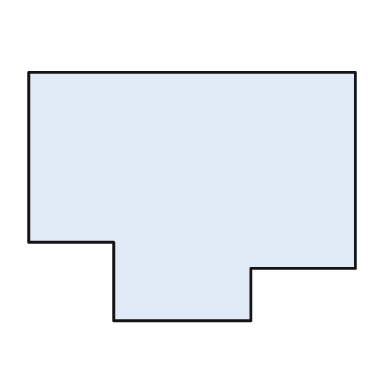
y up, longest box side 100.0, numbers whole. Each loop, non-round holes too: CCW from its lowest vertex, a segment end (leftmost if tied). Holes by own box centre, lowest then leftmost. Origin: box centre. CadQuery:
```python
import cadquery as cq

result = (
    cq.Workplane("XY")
    .moveTo(-24.0, -38.0)
    .lineTo(18.0, -38.0)
    .lineTo(18.0, -22.0)
    .lineTo(50.0, -22.0)
    .lineTo(50.0, 38.0)
    .lineTo(-50.0, 38.0)
    .lineTo(-50.0, -14.0)
    .lineTo(-24.0, -14.0)
    .close()
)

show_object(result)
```